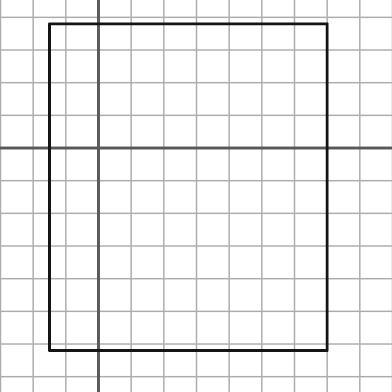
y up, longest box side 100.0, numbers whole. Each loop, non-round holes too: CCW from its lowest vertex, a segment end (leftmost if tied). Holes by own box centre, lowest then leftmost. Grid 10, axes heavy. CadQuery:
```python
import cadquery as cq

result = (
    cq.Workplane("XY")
    .moveTo(-15.0, -62.0)
    .lineTo(70.0, -62.0)
    .lineTo(70.0, 38.0)
    .lineTo(-15.0, 38.0)
    .close()
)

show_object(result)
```